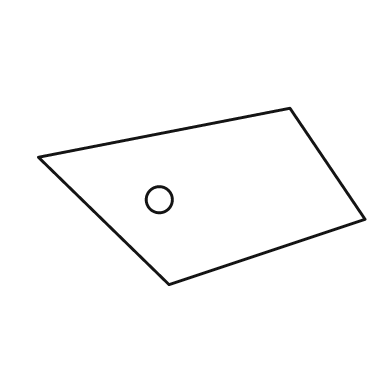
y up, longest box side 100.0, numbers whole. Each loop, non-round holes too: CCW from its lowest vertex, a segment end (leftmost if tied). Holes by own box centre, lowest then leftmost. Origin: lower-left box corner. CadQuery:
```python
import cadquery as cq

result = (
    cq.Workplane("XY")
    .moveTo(40.0, 0.0)
    .lineTo(100.0, 20.0)
    .lineTo(77.0, 54.0)
    .lineTo(0.0, 39.0)
    .close()
    .moveTo(37.0, 26.0)
    .circle(4.0)
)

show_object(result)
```